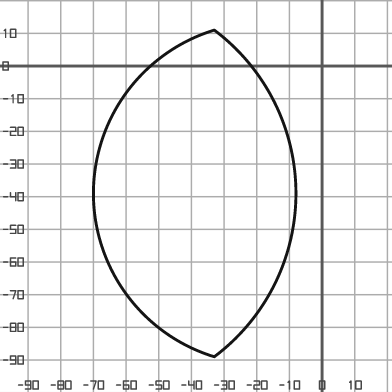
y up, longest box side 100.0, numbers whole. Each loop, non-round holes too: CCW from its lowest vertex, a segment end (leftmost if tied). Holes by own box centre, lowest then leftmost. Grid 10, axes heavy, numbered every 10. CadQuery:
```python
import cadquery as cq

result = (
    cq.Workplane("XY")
    .moveTo(-33.0, -89.0)
    .threePointArc((-8.0, -39.0), (-33.0, 11.0))
    .threePointArc((-70.0, -39.0), (-33.0, -89.0))
    .close()
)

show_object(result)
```